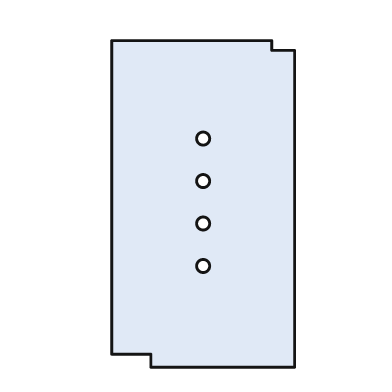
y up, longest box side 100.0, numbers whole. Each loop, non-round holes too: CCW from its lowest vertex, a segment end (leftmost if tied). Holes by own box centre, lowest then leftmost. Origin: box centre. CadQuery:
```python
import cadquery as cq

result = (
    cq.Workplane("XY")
    .moveTo(-16.0, -50.0)
    .lineTo(28.0, -50.0)
    .lineTo(28.0, 47.0)
    .lineTo(21.0, 47.0)
    .lineTo(21.0, 50.0)
    .lineTo(-28.0, 50.0)
    .lineTo(-28.0, -46.0)
    .lineTo(-16.0, -46.0)
    .close()
    .moveTo(0.0, -19.0)
    .circle(2.0)
    .moveTo(0.0, -6.0)
    .circle(2.0)
    .moveTo(0.0, 7.0)
    .circle(2.0)
    .moveTo(0.0, 20.0)
    .circle(2.0)
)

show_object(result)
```